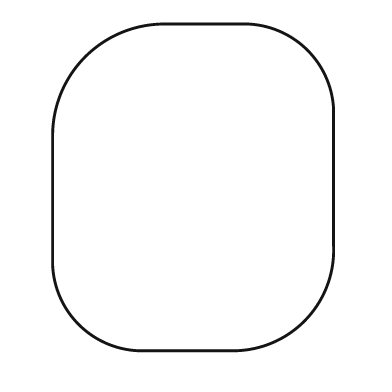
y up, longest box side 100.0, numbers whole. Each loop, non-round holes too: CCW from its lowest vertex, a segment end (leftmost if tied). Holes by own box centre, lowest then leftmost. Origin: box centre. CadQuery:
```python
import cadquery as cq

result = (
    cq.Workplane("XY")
    .moveTo(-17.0, -50.0)
    .lineTo(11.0, -50.0)
    .threePointArc((34.0, -41.0), (43.0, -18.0))
    .lineTo(43.0, 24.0)
    .threePointArc((35.0, 42.0), (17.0, 50.0))
    .lineTo(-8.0, 50.0)
    .threePointArc((-33.0, 40.0), (-43.0, 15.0))
    .lineTo(-43.0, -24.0)
    .threePointArc((-35.0, -42.0), (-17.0, -50.0))
    .close()
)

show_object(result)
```